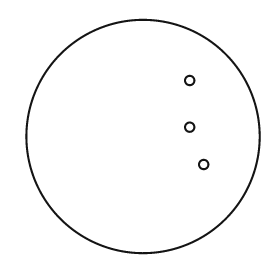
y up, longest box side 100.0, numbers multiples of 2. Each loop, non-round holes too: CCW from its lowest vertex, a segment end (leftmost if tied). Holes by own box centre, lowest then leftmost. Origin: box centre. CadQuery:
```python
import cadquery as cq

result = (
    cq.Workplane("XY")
    .moveTo(0.0, 0.0)
    .circle(50.0)
    .moveTo(26.0, -12.0)
    .circle(2.0)
    .moveTo(20.0, 4.0)
    .circle(2.0)
    .moveTo(20.0, 24.0)
    .circle(2.0)
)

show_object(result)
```